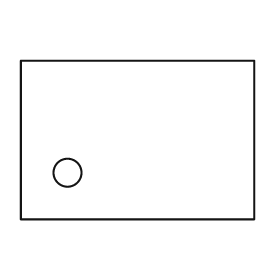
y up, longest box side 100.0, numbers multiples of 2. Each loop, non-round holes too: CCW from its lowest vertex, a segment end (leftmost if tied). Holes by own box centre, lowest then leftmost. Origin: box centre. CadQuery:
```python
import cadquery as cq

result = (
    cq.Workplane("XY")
    .moveTo(-50.0, -34.0)
    .lineTo(50.0, -34.0)
    .lineTo(50.0, 34.0)
    .lineTo(-50.0, 34.0)
    .close()
    .moveTo(-30.0, -14.0)
    .circle(6.0)
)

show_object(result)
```